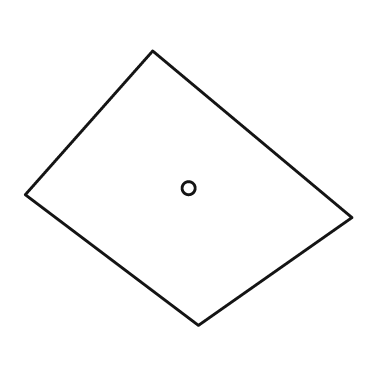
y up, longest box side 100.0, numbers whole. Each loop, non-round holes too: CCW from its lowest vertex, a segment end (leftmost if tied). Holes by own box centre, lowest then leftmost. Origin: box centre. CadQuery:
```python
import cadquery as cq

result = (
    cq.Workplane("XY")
    .moveTo(3.0, -42.0)
    .lineTo(50.0, -9.0)
    .lineTo(-11.0, 42.0)
    .lineTo(-50.0, -2.0)
    .close()
    .moveTo(0.0, 0.0)
    .circle(2.0)
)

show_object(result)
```